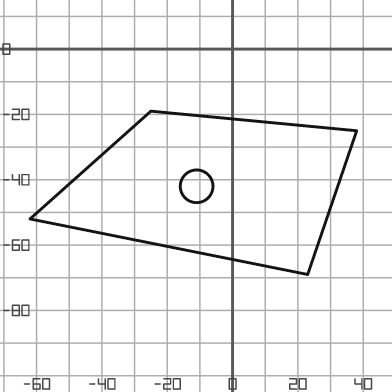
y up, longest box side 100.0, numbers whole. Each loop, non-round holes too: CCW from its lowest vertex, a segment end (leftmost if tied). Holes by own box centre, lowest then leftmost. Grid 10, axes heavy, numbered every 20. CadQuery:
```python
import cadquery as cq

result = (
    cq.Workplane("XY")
    .moveTo(23.0, -69.0)
    .lineTo(38.0, -25.0)
    .lineTo(-25.0, -19.0)
    .lineTo(-62.0, -52.0)
    .close()
    .moveTo(-11.0, -42.0)
    .circle(5.0)
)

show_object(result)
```